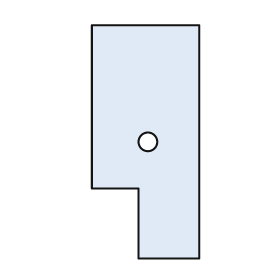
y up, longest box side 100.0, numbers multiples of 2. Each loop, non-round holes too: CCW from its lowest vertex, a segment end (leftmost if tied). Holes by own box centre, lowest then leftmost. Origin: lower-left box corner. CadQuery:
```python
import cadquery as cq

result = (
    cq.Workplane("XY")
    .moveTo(20.0, 0.0)
    .lineTo(46.0, 0.0)
    .lineTo(46.0, 100.0)
    .lineTo(0.0, 100.0)
    .lineTo(0.0, 30.0)
    .lineTo(20.0, 30.0)
    .close()
    .moveTo(24.0, 50.0)
    .circle(4.0)
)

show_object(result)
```